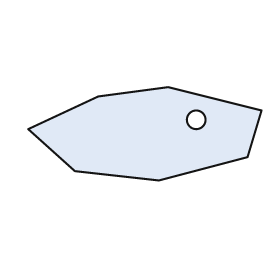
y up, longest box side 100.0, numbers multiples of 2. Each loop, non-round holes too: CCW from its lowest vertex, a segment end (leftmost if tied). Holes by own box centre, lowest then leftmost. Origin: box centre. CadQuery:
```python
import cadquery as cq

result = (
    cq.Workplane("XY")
    .moveTo(6.0, -20.0)
    .lineTo(44.0, -10.0)
    .lineTo(50.0, 10.0)
    .lineTo(10.0, 20.0)
    .lineTo(-20.0, 16.0)
    .lineTo(-50.0, 2.0)
    .lineTo(-30.0, -16.0)
    .close()
    .moveTo(22.0, 6.0)
    .circle(4.0)
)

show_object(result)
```